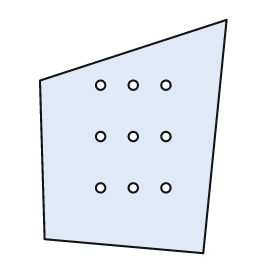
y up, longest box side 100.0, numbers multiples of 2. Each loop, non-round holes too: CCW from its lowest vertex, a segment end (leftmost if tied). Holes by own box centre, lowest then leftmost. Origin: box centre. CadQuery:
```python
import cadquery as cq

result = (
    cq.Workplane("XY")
    .moveTo(30.0, -50.0)
    .lineTo(40.0, 50.0)
    .lineTo(-40.0, 24.0)
    .lineTo(-38.0, -44.0)
    .close()
    .moveTo(-14.0, -22.0)
    .circle(2.0)
    .moveTo(0.0, -22.0)
    .circle(2.0)
    .moveTo(14.0, -22.0)
    .circle(2.0)
    .moveTo(-14.0, 0.0)
    .circle(2.0)
    .moveTo(0.0, 0.0)
    .circle(2.0)
    .moveTo(14.0, 0.0)
    .circle(2.0)
    .moveTo(-14.0, 22.0)
    .circle(2.0)
    .moveTo(0.0, 22.0)
    .circle(2.0)
    .moveTo(14.0, 22.0)
    .circle(2.0)
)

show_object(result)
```